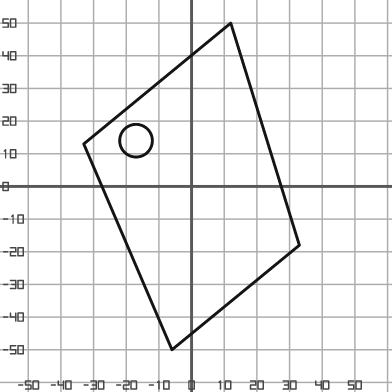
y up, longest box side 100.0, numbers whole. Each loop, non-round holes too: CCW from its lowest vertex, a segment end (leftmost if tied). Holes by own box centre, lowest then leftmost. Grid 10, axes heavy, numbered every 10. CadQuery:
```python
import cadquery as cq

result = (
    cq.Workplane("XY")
    .moveTo(-6.0, -50.0)
    .lineTo(33.0, -18.0)
    .lineTo(12.0, 50.0)
    .lineTo(-33.0, 13.0)
    .close()
    .moveTo(-17.0, 14.0)
    .circle(5.0)
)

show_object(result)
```